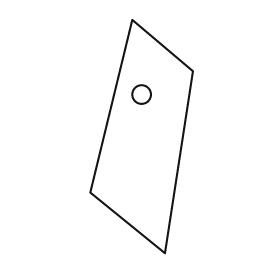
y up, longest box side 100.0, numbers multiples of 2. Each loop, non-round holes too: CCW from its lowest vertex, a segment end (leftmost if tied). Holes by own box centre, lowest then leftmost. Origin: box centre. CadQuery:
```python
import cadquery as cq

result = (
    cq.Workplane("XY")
    .moveTo(10.0, -50.0)
    .lineTo(22.0, 28.0)
    .lineTo(-4.0, 50.0)
    .lineTo(-22.0, -24.0)
    .close()
    .moveTo(0.0, 18.0)
    .circle(4.0)
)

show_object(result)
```